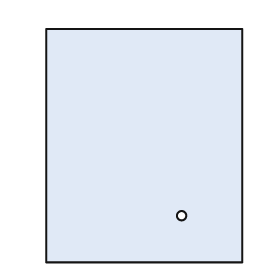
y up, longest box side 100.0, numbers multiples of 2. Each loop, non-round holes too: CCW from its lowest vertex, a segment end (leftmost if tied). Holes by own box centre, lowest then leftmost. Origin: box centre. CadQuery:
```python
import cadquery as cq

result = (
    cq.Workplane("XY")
    .moveTo(-42.0, -50.0)
    .lineTo(42.0, -50.0)
    .lineTo(42.0, 50.0)
    .lineTo(-42.0, 50.0)
    .close()
    .moveTo(16.0, -30.0)
    .circle(2.0)
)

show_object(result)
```